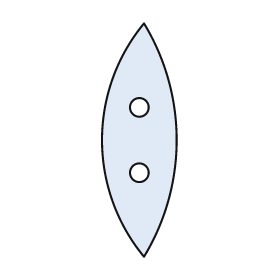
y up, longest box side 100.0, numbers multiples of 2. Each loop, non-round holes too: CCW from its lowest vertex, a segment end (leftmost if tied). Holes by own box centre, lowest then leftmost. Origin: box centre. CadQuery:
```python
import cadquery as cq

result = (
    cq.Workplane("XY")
    .moveTo(2.0, -50.0)
    .threePointArc((16.0, 0.0), (2.0, 50.0))
    .threePointArc((-16.0, 0.0), (2.0, -50.0))
    .close()
    .moveTo(0.0, -14.0)
    .circle(4.0)
    .moveTo(0.0, 14.0)
    .circle(4.0)
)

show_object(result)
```